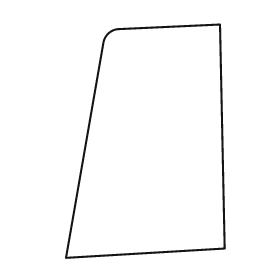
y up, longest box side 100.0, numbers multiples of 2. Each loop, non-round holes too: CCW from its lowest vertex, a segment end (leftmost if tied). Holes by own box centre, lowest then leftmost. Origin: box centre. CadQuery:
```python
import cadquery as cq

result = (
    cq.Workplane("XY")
    .moveTo(-34.0, -50.0)
    .lineTo(34.0, -46.0)
    .lineTo(32.0, 50.0)
    .lineTo(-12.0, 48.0)
    .threePointArc((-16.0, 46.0), (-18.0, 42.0))
    .close()
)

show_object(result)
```